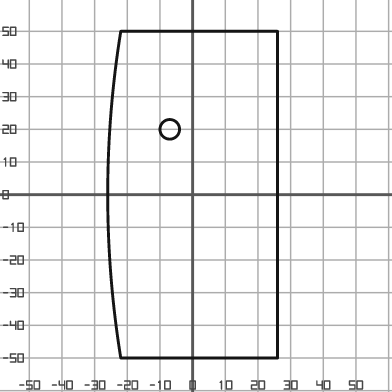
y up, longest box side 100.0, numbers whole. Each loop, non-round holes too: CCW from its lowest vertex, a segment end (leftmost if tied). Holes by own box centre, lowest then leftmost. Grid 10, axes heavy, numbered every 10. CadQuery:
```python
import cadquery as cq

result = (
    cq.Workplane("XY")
    .moveTo(-22.0, -50.0)
    .lineTo(26.0, -50.0)
    .lineTo(26.0, 50.0)
    .lineTo(-22.0, 50.0)
    .threePointArc((-26.0, 0.0), (-22.0, -50.0))
    .close()
    .moveTo(-7.0, 20.0)
    .circle(3.0)
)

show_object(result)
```